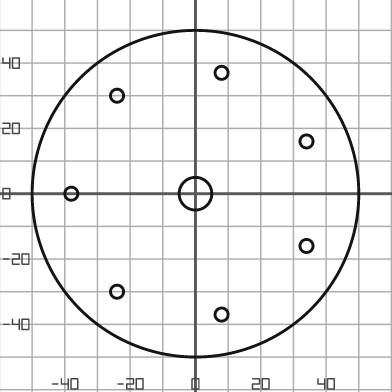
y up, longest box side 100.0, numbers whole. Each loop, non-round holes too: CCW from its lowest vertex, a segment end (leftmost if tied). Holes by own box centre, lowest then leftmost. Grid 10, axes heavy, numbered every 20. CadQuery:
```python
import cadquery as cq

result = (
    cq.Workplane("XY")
    .moveTo(0.0, 0.0)
    .circle(50.0)
    .moveTo(8.0, -37.0)
    .circle(2.0)
    .moveTo(-24.0, -30.0)
    .circle(2.0)
    .moveTo(34.0, -16.0)
    .circle(2.0)
    .moveTo(-38.0, 0.0)
    .circle(2.0)
    .moveTo(0.0, 0.0)
    .circle(5.0)
    .moveTo(34.0, 16.0)
    .circle(2.0)
    .moveTo(-24.0, 30.0)
    .circle(2.0)
    .moveTo(8.0, 37.0)
    .circle(2.0)
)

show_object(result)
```